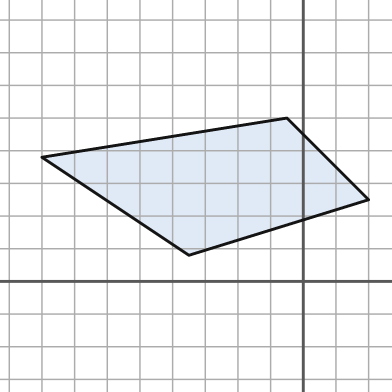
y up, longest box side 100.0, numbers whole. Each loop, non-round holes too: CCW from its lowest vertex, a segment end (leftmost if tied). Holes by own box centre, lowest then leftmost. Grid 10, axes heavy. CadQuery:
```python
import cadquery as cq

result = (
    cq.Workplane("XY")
    .moveTo(-35.0, 8.0)
    .lineTo(20.0, 25.0)
    .lineTo(-5.0, 50.0)
    .lineTo(-80.0, 38.0)
    .close()
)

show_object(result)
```